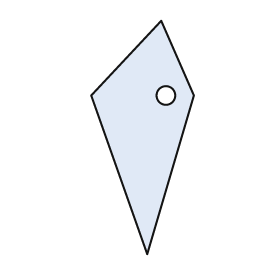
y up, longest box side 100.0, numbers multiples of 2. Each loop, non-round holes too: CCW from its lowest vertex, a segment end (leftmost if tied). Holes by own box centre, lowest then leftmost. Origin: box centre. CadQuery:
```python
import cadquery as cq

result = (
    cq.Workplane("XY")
    .moveTo(2.0, -50.0)
    .lineTo(22.0, 18.0)
    .lineTo(8.0, 50.0)
    .lineTo(-22.0, 18.0)
    .close()
    .moveTo(10.0, 18.0)
    .circle(4.0)
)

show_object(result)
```